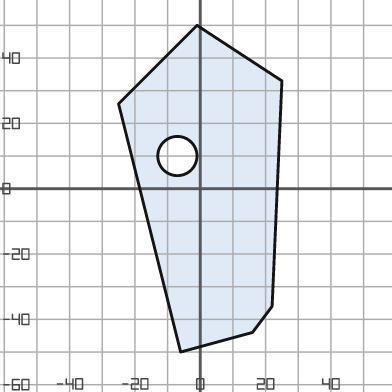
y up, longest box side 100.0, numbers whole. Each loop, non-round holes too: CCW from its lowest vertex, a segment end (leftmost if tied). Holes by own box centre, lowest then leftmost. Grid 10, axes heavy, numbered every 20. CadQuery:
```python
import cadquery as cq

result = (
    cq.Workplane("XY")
    .moveTo(-6.0, -50.0)
    .lineTo(16.0, -44.0)
    .lineTo(22.0, -36.0)
    .lineTo(25.0, 33.0)
    .lineTo(-1.0, 50.0)
    .lineTo(-25.0, 26.0)
    .close()
    .moveTo(-7.0, 10.0)
    .circle(6.0)
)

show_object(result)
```